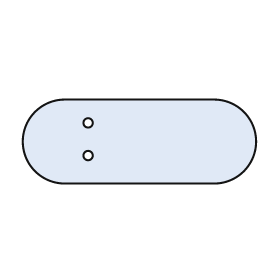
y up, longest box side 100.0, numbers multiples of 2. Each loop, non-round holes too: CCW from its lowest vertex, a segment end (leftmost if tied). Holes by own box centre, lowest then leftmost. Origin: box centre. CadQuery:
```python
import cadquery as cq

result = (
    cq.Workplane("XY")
    .moveTo(-32.0, -18.0)
    .lineTo(32.0, -18.0)
    .threePointArc((50.0, 0.0), (32.0, 18.0))
    .lineTo(-32.0, 18.0)
    .threePointArc((-50.0, 0.0), (-32.0, -18.0))
    .close()
    .moveTo(-22.0, -6.0)
    .circle(2.0)
    .moveTo(-22.0, 8.0)
    .circle(2.0)
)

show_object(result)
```